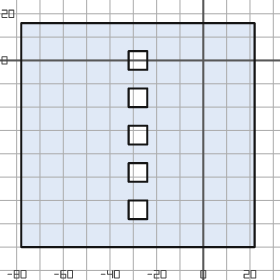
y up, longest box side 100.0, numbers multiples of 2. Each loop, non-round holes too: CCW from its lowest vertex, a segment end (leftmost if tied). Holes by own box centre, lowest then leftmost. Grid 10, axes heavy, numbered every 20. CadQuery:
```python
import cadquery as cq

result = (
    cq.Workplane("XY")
    .moveTo(-78.0, -80.0)
    .lineTo(22.0, -80.0)
    .lineTo(22.0, 16.0)
    .lineTo(-78.0, 16.0)
    .close()
    .moveTo(-32.0, -68.0)
    .lineTo(-24.0, -68.0)
    .lineTo(-24.0, -60.0)
    .lineTo(-32.0, -60.0)
    .close()
    .moveTo(-32.0, -52.0)
    .lineTo(-24.0, -52.0)
    .lineTo(-24.0, -44.0)
    .lineTo(-32.0, -44.0)
    .close()
    .moveTo(-32.0, -36.0)
    .lineTo(-24.0, -36.0)
    .lineTo(-24.0, -28.0)
    .lineTo(-32.0, -28.0)
    .close()
    .moveTo(-32.0, -20.0)
    .lineTo(-24.0, -20.0)
    .lineTo(-24.0, -12.0)
    .lineTo(-32.0, -12.0)
    .close()
    .moveTo(-32.0, -4.0)
    .lineTo(-24.0, -4.0)
    .lineTo(-24.0, 4.0)
    .lineTo(-32.0, 4.0)
    .close()
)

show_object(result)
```